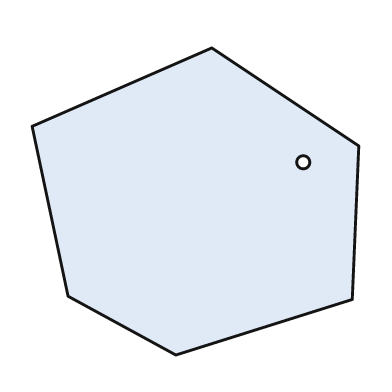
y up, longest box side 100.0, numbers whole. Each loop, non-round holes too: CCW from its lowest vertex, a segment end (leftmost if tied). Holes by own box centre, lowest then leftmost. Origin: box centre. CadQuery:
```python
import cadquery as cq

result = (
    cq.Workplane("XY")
    .moveTo(-6.0, -47.0)
    .lineTo(48.0, -30.0)
    .lineTo(50.0, 17.0)
    .lineTo(5.0, 47.0)
    .lineTo(-50.0, 23.0)
    .lineTo(-39.0, -29.0)
    .close()
    .moveTo(33.0, 12.0)
    .circle(2.0)
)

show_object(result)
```